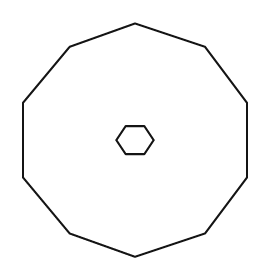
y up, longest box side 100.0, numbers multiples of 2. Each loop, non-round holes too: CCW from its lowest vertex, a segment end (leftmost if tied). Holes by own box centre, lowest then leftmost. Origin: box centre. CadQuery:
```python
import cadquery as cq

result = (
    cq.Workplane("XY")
    .moveTo(0.0, -50.0)
    .lineTo(30.0, -40.0)
    .lineTo(48.0, -16.0)
    .lineTo(48.0, 16.0)
    .lineTo(30.0, 40.0)
    .lineTo(0.0, 50.0)
    .lineTo(-28.0, 40.0)
    .lineTo(-48.0, 16.0)
    .lineTo(-48.0, -16.0)
    .lineTo(-28.0, -40.0)
    .close()
    .moveTo(-4.0, -6.0)
    .lineTo(4.0, -6.0)
    .lineTo(8.0, 0.0)
    .lineTo(4.0, 6.0)
    .lineTo(-4.0, 6.0)
    .lineTo(-8.0, 0.0)
    .close()
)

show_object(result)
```